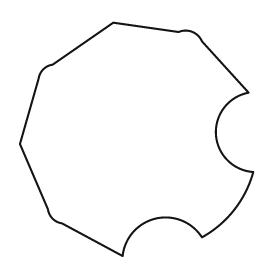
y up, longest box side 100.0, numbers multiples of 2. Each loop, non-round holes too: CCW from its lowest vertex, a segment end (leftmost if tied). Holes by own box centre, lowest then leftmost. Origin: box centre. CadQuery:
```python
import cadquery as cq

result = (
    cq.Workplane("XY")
    .moveTo(-6.0, -50.0)
    .threePointArc((8.0, -34.0), (28.0, -42.0))
    .threePointArc((42.0, -30.0), (50.0, -14.0))
    .threePointArc((34.0, 2.0), (48.0, 20.0))
    .lineTo(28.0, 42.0)
    .threePointArc((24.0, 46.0), (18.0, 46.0))
    .lineTo(-10.0, 50.0)
    .lineTo(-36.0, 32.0)
    .threePointArc((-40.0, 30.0), (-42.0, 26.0))
    .lineTo(-50.0, -2.0)
    .lineTo(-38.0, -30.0)
    .threePointArc((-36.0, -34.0), (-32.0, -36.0))
    .close()
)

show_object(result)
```